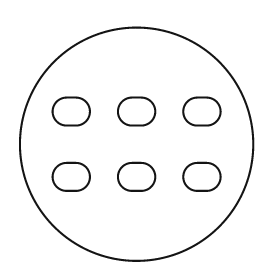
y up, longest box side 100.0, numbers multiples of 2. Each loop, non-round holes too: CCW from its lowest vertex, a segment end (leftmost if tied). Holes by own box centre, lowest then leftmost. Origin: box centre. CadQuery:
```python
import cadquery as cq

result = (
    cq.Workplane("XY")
    .moveTo(0.0, 0.0)
    .circle(50.0)
    .moveTo(-30.0, -20.0)
    .lineTo(-26.0, -20.0)
    .threePointArc((-20.0, -14.0), (-26.0, -8.0))
    .lineTo(-30.0, -8.0)
    .threePointArc((-36.0, -14.0), (-30.0, -20.0))
    .close()
    .moveTo(-2.0, -20.0)
    .lineTo(2.0, -20.0)
    .threePointArc((8.0, -14.0), (2.0, -8.0))
    .lineTo(-2.0, -8.0)
    .threePointArc((-8.0, -14.0), (-2.0, -20.0))
    .close()
    .moveTo(26.0, -20.0)
    .lineTo(30.0, -20.0)
    .threePointArc((36.0, -14.0), (30.0, -8.0))
    .lineTo(26.0, -8.0)
    .threePointArc((20.0, -14.0), (26.0, -20.0))
    .close()
    .moveTo(-30.0, 8.0)
    .lineTo(-26.0, 8.0)
    .threePointArc((-20.0, 14.0), (-26.0, 20.0))
    .lineTo(-30.0, 20.0)
    .threePointArc((-36.0, 14.0), (-30.0, 8.0))
    .close()
    .moveTo(-2.0, 8.0)
    .lineTo(2.0, 8.0)
    .threePointArc((8.0, 14.0), (2.0, 20.0))
    .lineTo(-2.0, 20.0)
    .threePointArc((-8.0, 14.0), (-2.0, 8.0))
    .close()
    .moveTo(26.0, 8.0)
    .lineTo(30.0, 8.0)
    .threePointArc((36.0, 14.0), (30.0, 20.0))
    .lineTo(26.0, 20.0)
    .threePointArc((20.0, 14.0), (26.0, 8.0))
    .close()
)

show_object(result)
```